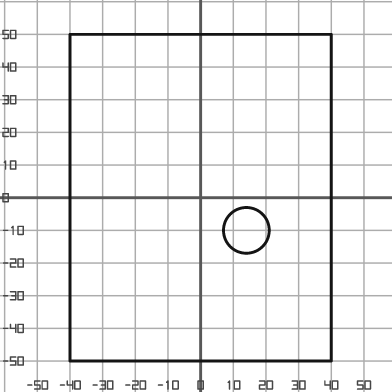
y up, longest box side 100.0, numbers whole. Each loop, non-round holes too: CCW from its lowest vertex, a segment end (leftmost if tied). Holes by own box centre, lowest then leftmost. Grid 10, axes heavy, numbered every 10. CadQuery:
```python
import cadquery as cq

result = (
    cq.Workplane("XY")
    .moveTo(-40.0, -50.0)
    .lineTo(40.0, -50.0)
    .lineTo(40.0, 50.0)
    .lineTo(-40.0, 50.0)
    .close()
    .moveTo(14.0, -10.0)
    .circle(7.0)
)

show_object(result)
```